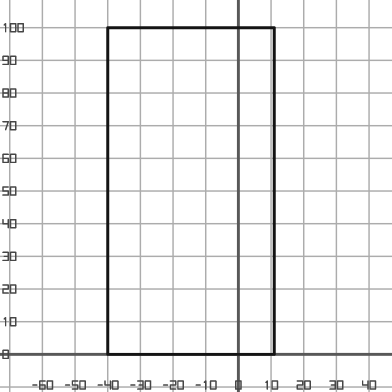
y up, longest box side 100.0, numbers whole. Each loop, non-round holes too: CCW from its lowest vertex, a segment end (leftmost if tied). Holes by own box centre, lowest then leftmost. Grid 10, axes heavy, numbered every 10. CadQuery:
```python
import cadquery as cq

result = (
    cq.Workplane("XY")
    .moveTo(-40.0, 0.0)
    .lineTo(11.0, 0.0)
    .lineTo(11.0, 100.0)
    .lineTo(-40.0, 100.0)
    .close()
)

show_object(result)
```